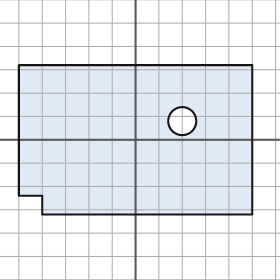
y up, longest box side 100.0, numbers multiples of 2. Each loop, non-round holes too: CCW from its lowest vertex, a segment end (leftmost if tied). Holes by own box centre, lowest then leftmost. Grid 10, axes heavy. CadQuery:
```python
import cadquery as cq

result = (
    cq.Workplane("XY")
    .moveTo(-40.0, -32.0)
    .lineTo(50.0, -32.0)
    .lineTo(50.0, 32.0)
    .lineTo(-50.0, 32.0)
    .lineTo(-50.0, -24.0)
    .lineTo(-40.0, -24.0)
    .close()
    .moveTo(20.0, 8.0)
    .circle(6.0)
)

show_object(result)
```